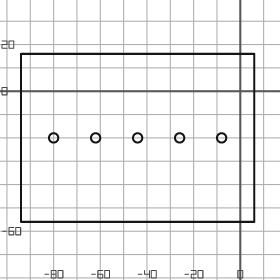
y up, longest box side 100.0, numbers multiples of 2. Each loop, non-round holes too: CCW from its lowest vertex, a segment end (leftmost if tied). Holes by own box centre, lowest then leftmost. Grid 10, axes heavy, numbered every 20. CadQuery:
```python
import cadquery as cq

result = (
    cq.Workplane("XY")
    .moveTo(-94.0, -56.0)
    .lineTo(6.0, -56.0)
    .lineTo(6.0, 16.0)
    .lineTo(-94.0, 16.0)
    .close()
    .moveTo(-80.0, -20.0)
    .circle(2.0)
    .moveTo(-62.0, -20.0)
    .circle(2.0)
    .moveTo(-44.0, -20.0)
    .circle(2.0)
    .moveTo(-26.0, -20.0)
    .circle(2.0)
    .moveTo(-8.0, -20.0)
    .circle(2.0)
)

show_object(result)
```